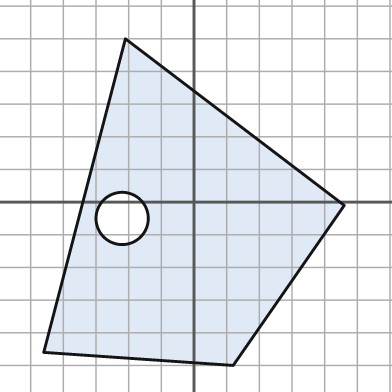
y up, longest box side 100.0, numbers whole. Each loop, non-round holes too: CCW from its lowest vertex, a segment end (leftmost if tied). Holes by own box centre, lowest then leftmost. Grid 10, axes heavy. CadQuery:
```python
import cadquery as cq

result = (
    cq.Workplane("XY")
    .moveTo(12.0, -50.0)
    .lineTo(46.0, -1.0)
    .lineTo(-21.0, 50.0)
    .lineTo(-46.0, -46.0)
    .close()
    .moveTo(-22.0, -5.0)
    .circle(8.0)
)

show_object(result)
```